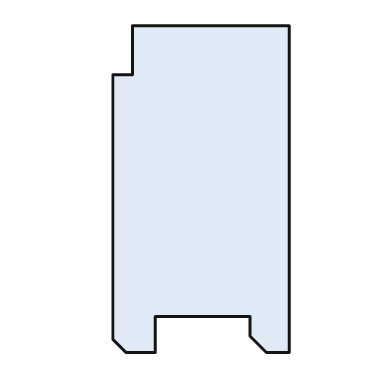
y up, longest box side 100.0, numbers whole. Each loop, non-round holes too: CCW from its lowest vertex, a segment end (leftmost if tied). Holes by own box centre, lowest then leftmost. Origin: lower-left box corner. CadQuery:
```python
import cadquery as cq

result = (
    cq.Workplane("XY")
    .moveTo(4.0, 0.0)
    .lineTo(13.0, 0.0)
    .lineTo(13.0, 11.0)
    .lineTo(42.0, 11.0)
    .lineTo(42.0, 5.0)
    .lineTo(47.0, 0.0)
    .lineTo(54.0, 0.0)
    .lineTo(54.0, 100.0)
    .lineTo(6.0, 100.0)
    .lineTo(6.0, 85.0)
    .lineTo(0.0, 85.0)
    .lineTo(0.0, 4.0)
    .close()
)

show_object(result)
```